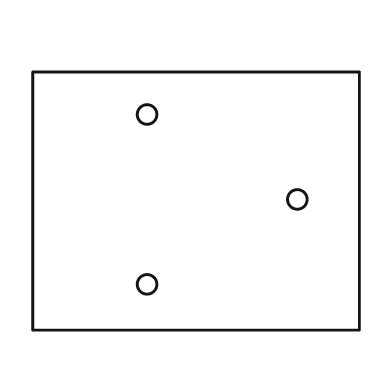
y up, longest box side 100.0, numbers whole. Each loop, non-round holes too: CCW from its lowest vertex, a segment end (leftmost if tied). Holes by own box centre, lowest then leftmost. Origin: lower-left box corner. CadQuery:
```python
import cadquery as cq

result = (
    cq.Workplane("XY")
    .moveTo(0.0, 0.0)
    .lineTo(100.0, 0.0)
    .lineTo(100.0, 79.0)
    .lineTo(0.0, 79.0)
    .close()
    .moveTo(35.0, 14.0)
    .circle(3.0)
    .moveTo(81.0, 40.0)
    .circle(3.0)
    .moveTo(35.0, 66.0)
    .circle(3.0)
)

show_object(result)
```